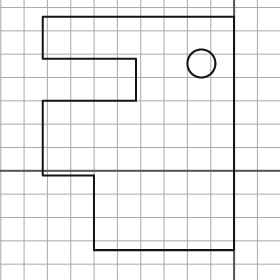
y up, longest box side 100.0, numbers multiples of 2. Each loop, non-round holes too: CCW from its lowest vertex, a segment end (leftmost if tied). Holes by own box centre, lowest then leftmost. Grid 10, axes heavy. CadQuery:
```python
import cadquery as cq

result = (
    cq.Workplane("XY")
    .moveTo(-60.0, -34.0)
    .lineTo(0.0, -34.0)
    .lineTo(0.0, 66.0)
    .lineTo(-82.0, 66.0)
    .lineTo(-82.0, 48.0)
    .lineTo(-42.0, 48.0)
    .lineTo(-42.0, 30.0)
    .lineTo(-82.0, 30.0)
    .lineTo(-82.0, -2.0)
    .lineTo(-60.0, -2.0)
    .close()
    .moveTo(-14.0, 46.0)
    .circle(6.0)
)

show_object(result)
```